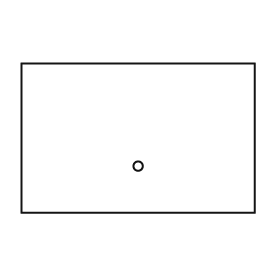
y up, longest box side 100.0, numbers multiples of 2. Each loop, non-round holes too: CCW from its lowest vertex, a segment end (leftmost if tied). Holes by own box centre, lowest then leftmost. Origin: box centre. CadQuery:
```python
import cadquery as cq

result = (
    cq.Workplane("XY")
    .moveTo(-50.0, -32.0)
    .lineTo(50.0, -32.0)
    .lineTo(50.0, 32.0)
    .lineTo(-50.0, 32.0)
    .close()
    .moveTo(0.0, -12.0)
    .circle(2.0)
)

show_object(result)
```